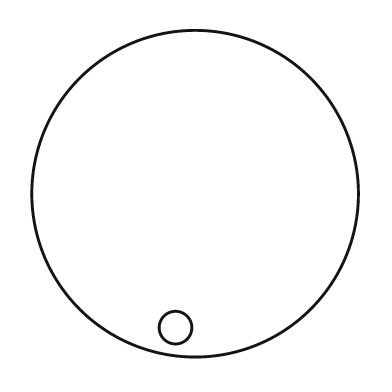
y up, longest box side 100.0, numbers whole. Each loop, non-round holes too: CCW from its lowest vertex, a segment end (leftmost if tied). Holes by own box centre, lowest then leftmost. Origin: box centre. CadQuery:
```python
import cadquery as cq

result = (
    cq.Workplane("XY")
    .moveTo(0.0, 0.0)
    .circle(50.0)
    .moveTo(-6.0, -41.0)
    .circle(5.0)
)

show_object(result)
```